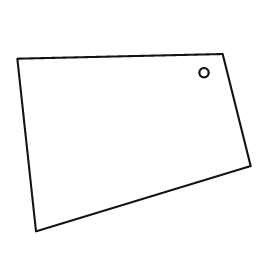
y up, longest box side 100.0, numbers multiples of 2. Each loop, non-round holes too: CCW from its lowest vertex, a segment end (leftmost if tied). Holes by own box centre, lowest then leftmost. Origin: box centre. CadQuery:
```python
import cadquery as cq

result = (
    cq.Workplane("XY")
    .moveTo(-42.0, -38.0)
    .lineTo(50.0, -10.0)
    .lineTo(38.0, 38.0)
    .lineTo(-50.0, 36.0)
    .close()
    .moveTo(30.0, 30.0)
    .circle(2.0)
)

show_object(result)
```